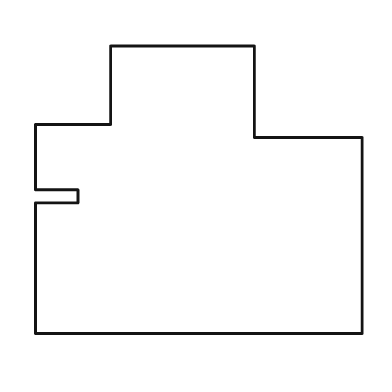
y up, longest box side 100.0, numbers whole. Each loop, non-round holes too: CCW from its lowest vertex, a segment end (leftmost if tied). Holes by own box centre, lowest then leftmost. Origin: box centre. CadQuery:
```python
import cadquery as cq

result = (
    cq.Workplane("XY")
    .moveTo(-50.0, -44.0)
    .lineTo(50.0, -44.0)
    .lineTo(50.0, 16.0)
    .lineTo(17.0, 16.0)
    .lineTo(17.0, 44.0)
    .lineTo(-27.0, 44.0)
    .lineTo(-27.0, 20.0)
    .lineTo(-50.0, 20.0)
    .lineTo(-50.0, 0.0)
    .lineTo(-37.0, 0.0)
    .lineTo(-37.0, -4.0)
    .lineTo(-50.0, -4.0)
    .close()
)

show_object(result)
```